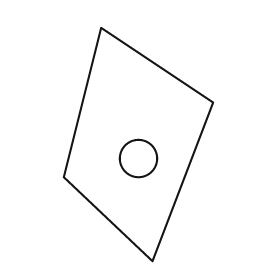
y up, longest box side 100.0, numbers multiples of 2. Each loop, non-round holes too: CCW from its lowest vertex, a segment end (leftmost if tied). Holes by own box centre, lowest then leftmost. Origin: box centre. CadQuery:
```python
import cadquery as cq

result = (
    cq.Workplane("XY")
    .moveTo(6.0, -50.0)
    .lineTo(32.0, 18.0)
    .lineTo(-16.0, 50.0)
    .lineTo(-32.0, -14.0)
    .close()
    .moveTo(0.0, -6.0)
    .circle(8.0)
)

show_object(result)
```